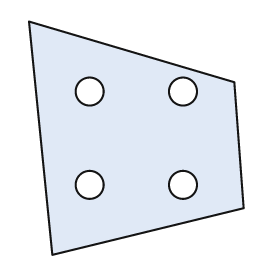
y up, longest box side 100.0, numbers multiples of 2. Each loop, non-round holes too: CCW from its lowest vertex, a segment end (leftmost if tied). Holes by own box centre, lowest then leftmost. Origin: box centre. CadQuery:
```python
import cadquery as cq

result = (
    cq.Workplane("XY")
    .moveTo(-36.0, -50.0)
    .lineTo(46.0, -30.0)
    .lineTo(42.0, 24.0)
    .lineTo(-46.0, 50.0)
    .close()
    .moveTo(-20.0, -20.0)
    .circle(6.0)
    .moveTo(20.0, -20.0)
    .circle(6.0)
    .moveTo(-20.0, 20.0)
    .circle(6.0)
    .moveTo(20.0, 20.0)
    .circle(6.0)
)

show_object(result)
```